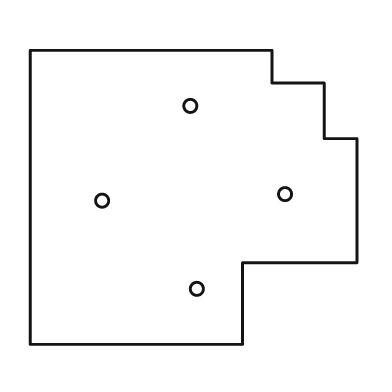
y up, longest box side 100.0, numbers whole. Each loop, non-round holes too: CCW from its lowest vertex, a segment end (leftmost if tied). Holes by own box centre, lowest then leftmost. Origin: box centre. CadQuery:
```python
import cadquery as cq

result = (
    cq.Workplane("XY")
    .moveTo(-50.0, -45.0)
    .lineTo(15.0, -45.0)
    .lineTo(15.0, -20.0)
    .lineTo(50.0, -20.0)
    .lineTo(50.0, 18.0)
    .lineTo(40.0, 18.0)
    .lineTo(40.0, 35.0)
    .lineTo(24.0, 35.0)
    .lineTo(24.0, 45.0)
    .lineTo(-50.0, 45.0)
    .close()
    .moveTo(1.0, -28.0)
    .circle(2.0)
    .moveTo(-28.0, -1.0)
    .circle(2.0)
    .moveTo(28.0, 1.0)
    .circle(2.0)
    .moveTo(-1.0, 28.0)
    .circle(2.0)
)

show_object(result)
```